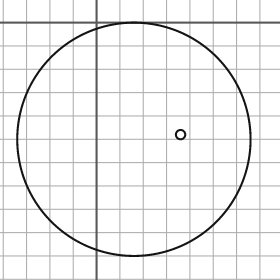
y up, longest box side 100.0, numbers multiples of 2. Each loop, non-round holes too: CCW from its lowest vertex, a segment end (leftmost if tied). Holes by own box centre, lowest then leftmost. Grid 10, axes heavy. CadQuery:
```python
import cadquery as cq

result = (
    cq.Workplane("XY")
    .moveTo(16.0, -50.0)
    .circle(50.0)
    .moveTo(36.0, -48.0)
    .circle(2.0)
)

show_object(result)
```